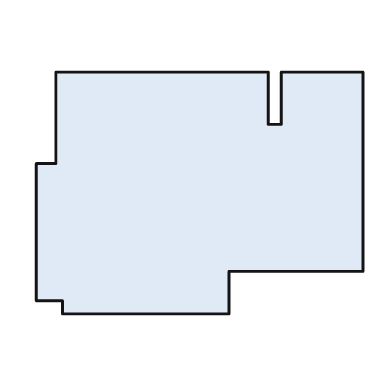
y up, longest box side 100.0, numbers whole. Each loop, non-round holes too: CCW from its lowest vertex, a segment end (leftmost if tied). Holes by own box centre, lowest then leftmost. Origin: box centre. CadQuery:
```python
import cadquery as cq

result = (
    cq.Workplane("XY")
    .moveTo(-42.0, -37.0)
    .lineTo(9.0, -37.0)
    .lineTo(9.0, -24.0)
    .lineTo(50.0, -24.0)
    .lineTo(50.0, 37.0)
    .lineTo(25.0, 37.0)
    .lineTo(25.0, 21.0)
    .lineTo(21.0, 21.0)
    .lineTo(21.0, 37.0)
    .lineTo(-44.0, 37.0)
    .lineTo(-44.0, 9.0)
    .lineTo(-50.0, 9.0)
    .lineTo(-50.0, -33.0)
    .lineTo(-42.0, -33.0)
    .close()
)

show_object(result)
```